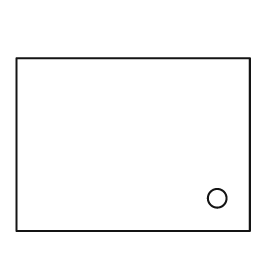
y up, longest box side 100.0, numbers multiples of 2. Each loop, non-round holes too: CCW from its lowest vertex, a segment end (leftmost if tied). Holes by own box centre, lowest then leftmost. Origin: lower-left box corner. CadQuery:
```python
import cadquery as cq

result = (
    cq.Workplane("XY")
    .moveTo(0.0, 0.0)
    .lineTo(100.0, 0.0)
    .lineTo(100.0, 74.0)
    .lineTo(0.0, 74.0)
    .close()
    .moveTo(86.0, 14.0)
    .circle(4.0)
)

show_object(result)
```